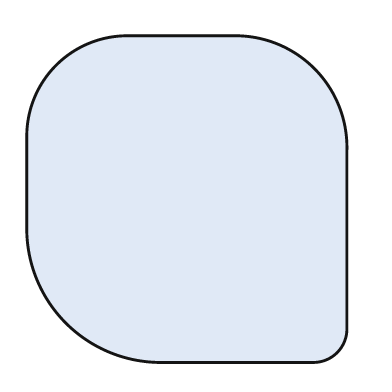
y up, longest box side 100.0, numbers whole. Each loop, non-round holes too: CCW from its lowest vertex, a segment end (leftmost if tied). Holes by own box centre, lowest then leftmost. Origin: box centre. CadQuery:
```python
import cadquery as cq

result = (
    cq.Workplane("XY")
    .moveTo(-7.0, -50.0)
    .lineTo(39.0, -50.0)
    .threePointArc((46.0, -47.0), (49.0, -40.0))
    .lineTo(49.0, 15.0)
    .threePointArc((39.0, 40.0), (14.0, 50.0))
    .lineTo(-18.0, 50.0)
    .threePointArc((-40.0, 41.0), (-49.0, 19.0))
    .lineTo(-49.0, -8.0)
    .threePointArc((-37.0, -38.0), (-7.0, -50.0))
    .close()
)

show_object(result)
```